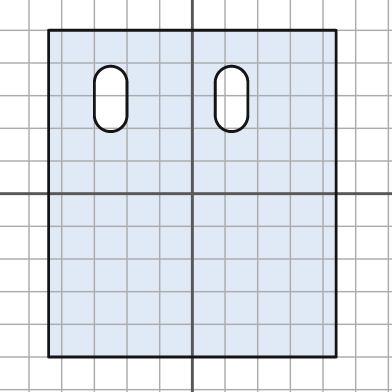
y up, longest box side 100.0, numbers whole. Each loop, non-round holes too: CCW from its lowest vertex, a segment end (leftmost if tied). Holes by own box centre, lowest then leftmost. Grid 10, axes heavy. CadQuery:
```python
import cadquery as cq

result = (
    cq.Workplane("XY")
    .moveTo(-44.0, -50.0)
    .lineTo(44.0, -50.0)
    .lineTo(44.0, 50.0)
    .lineTo(-44.0, 50.0)
    .close()
    .moveTo(-30.0, 24.0)
    .threePointArc((-25.0, 19.0), (-20.0, 24.0))
    .lineTo(-20.0, 34.0)
    .threePointArc((-25.0, 39.0), (-30.0, 34.0))
    .close()
    .moveTo(7.0, 24.0)
    .threePointArc((12.0, 19.0), (17.0, 24.0))
    .lineTo(17.0, 34.0)
    .threePointArc((12.0, 39.0), (7.0, 34.0))
    .close()
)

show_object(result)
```